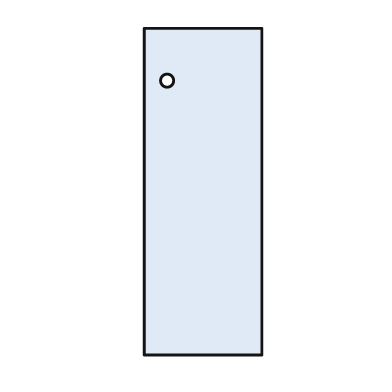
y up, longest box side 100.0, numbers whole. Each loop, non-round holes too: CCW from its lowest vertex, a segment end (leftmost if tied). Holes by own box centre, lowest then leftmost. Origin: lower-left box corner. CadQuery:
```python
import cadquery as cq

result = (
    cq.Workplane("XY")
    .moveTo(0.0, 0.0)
    .lineTo(36.0, 0.0)
    .lineTo(36.0, 100.0)
    .lineTo(0.0, 100.0)
    .close()
    .moveTo(7.0, 84.0)
    .circle(2.0)
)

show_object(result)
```